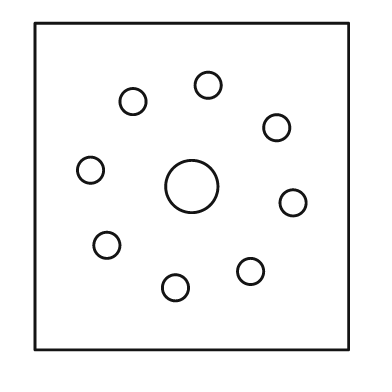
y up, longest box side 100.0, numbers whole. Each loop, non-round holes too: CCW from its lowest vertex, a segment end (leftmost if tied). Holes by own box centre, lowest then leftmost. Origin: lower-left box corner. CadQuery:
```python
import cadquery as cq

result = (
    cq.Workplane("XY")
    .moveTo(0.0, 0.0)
    .lineTo(96.0, 0.0)
    .lineTo(96.0, 100.0)
    .lineTo(0.0, 100.0)
    .close()
    .moveTo(43.0, 19.0)
    .circle(4.0)
    .moveTo(66.0, 24.0)
    .circle(4.0)
    .moveTo(22.0, 32.0)
    .circle(4.0)
    .moveTo(79.0, 45.0)
    .circle(4.0)
    .moveTo(48.0, 50.0)
    .circle(8.0)
    .moveTo(17.0, 55.0)
    .circle(4.0)
    .moveTo(74.0, 68.0)
    .circle(4.0)
    .moveTo(30.0, 76.0)
    .circle(4.0)
    .moveTo(53.0, 81.0)
    .circle(4.0)
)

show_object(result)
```